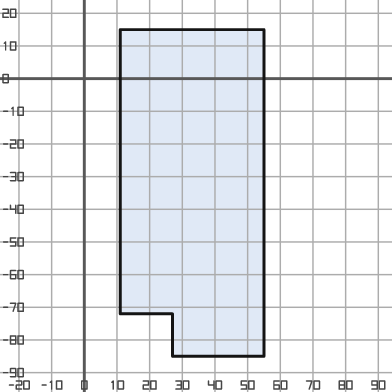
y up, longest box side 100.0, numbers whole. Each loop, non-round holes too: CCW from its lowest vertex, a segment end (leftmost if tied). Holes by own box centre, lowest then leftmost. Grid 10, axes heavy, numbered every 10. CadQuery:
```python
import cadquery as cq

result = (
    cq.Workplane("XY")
    .moveTo(27.0, -85.0)
    .lineTo(55.0, -85.0)
    .lineTo(55.0, 15.0)
    .lineTo(11.0, 15.0)
    .lineTo(11.0, -72.0)
    .lineTo(27.0, -72.0)
    .close()
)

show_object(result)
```